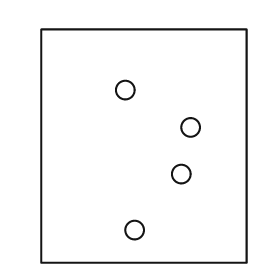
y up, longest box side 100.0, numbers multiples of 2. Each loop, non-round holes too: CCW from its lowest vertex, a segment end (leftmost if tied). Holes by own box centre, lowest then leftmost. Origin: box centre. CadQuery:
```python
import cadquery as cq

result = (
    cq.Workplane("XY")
    .moveTo(-44.0, -50.0)
    .lineTo(44.0, -50.0)
    .lineTo(44.0, 50.0)
    .lineTo(-44.0, 50.0)
    .close()
    .moveTo(-4.0, -36.0)
    .circle(4.0)
    .moveTo(16.0, -12.0)
    .circle(4.0)
    .moveTo(20.0, 8.0)
    .circle(4.0)
    .moveTo(-8.0, 24.0)
    .circle(4.0)
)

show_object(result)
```